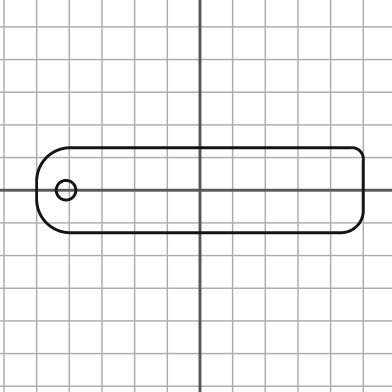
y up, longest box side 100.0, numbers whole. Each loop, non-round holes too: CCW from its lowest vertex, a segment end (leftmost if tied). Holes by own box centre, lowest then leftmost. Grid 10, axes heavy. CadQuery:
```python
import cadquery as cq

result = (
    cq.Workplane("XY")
    .moveTo(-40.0, -13.0)
    .lineTo(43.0, -13.0)
    .threePointArc((48.0, -11.0), (50.0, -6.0))
    .lineTo(50.0, 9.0)
    .threePointArc((49.0, 12.0), (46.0, 13.0))
    .lineTo(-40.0, 13.0)
    .threePointArc((-47.0, 10.0), (-50.0, 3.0))
    .lineTo(-50.0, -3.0)
    .threePointArc((-47.0, -10.0), (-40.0, -13.0))
    .close()
    .moveTo(-41.0, 0.0)
    .circle(3.0)
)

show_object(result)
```